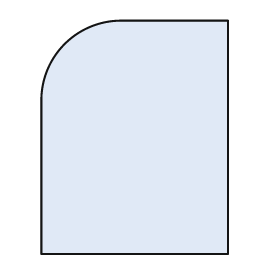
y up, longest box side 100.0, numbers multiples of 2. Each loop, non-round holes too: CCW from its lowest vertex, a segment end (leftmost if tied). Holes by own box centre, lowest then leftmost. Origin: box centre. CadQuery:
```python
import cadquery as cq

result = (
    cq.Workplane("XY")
    .moveTo(-40.0, -50.0)
    .lineTo(40.0, -50.0)
    .lineTo(40.0, 50.0)
    .lineTo(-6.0, 50.0)
    .threePointArc((-30.0, 40.0), (-40.0, 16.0))
    .close()
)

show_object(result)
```